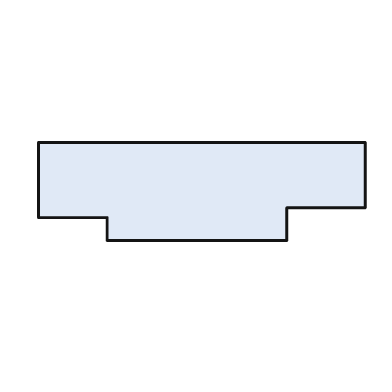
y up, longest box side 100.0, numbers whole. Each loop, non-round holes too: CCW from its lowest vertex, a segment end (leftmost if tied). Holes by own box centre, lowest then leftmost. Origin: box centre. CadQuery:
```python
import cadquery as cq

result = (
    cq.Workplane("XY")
    .moveTo(-29.0, -15.0)
    .lineTo(26.0, -15.0)
    .lineTo(26.0, -5.0)
    .lineTo(50.0, -5.0)
    .lineTo(50.0, 15.0)
    .lineTo(-50.0, 15.0)
    .lineTo(-50.0, -8.0)
    .lineTo(-29.0, -8.0)
    .close()
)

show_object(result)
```